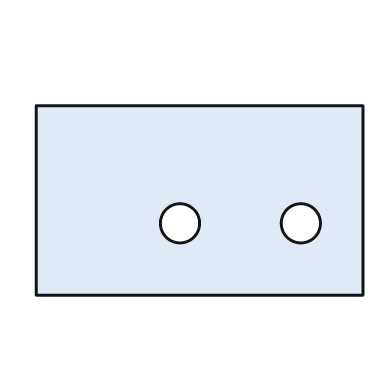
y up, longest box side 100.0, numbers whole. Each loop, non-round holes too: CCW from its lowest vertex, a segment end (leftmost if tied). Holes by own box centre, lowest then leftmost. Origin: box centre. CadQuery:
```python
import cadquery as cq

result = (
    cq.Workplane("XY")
    .moveTo(-50.0, -29.0)
    .lineTo(50.0, -29.0)
    .lineTo(50.0, 29.0)
    .lineTo(-50.0, 29.0)
    .close()
    .moveTo(-6.0, -7.0)
    .circle(6.0)
    .moveTo(31.0, -7.0)
    .circle(6.0)
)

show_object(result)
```